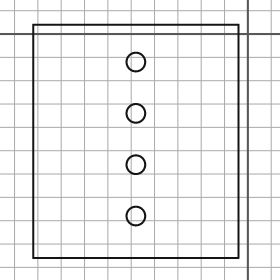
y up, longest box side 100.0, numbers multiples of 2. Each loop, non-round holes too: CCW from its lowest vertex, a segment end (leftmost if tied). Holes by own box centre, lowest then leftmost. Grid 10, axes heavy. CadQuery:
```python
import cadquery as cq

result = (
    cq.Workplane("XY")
    .moveTo(-92.0, -96.0)
    .lineTo(-4.0, -96.0)
    .lineTo(-4.0, 4.0)
    .lineTo(-92.0, 4.0)
    .close()
    .moveTo(-48.0, -78.0)
    .circle(4.0)
    .moveTo(-48.0, -56.0)
    .circle(4.0)
    .moveTo(-48.0, -34.0)
    .circle(4.0)
    .moveTo(-48.0, -12.0)
    .circle(4.0)
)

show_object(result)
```